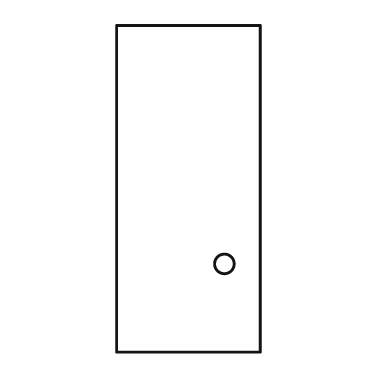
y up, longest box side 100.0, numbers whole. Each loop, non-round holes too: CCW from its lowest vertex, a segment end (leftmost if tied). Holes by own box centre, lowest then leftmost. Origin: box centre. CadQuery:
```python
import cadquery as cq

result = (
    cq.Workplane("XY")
    .moveTo(-22.0, -50.0)
    .lineTo(22.0, -50.0)
    .lineTo(22.0, 50.0)
    .lineTo(-22.0, 50.0)
    .close()
    .moveTo(11.0, -23.0)
    .circle(3.0)
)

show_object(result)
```